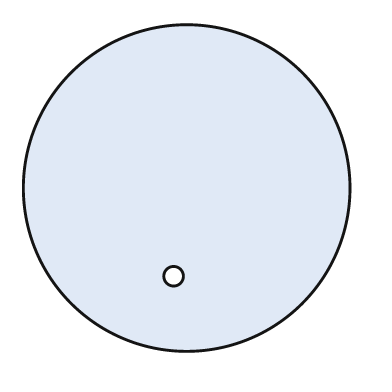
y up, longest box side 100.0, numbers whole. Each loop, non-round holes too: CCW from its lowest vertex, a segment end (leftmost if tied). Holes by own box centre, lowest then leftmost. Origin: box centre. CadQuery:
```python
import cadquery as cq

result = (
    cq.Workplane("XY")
    .moveTo(0.0, 0.0)
    .circle(50.0)
    .moveTo(-4.0, -27.0)
    .circle(3.0)
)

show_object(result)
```